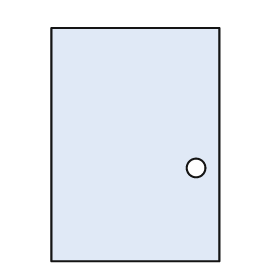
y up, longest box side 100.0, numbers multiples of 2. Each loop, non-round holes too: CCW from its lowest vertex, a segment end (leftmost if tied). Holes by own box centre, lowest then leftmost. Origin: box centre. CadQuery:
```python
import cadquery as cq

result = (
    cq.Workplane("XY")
    .moveTo(-36.0, -50.0)
    .lineTo(36.0, -50.0)
    .lineTo(36.0, 50.0)
    .lineTo(-36.0, 50.0)
    .close()
    .moveTo(26.0, -10.0)
    .circle(4.0)
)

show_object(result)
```